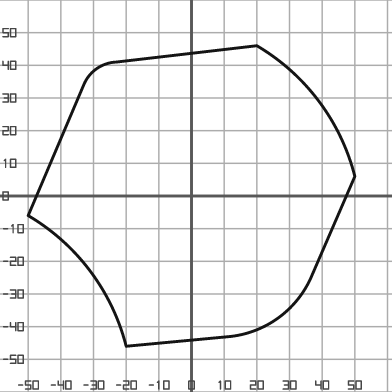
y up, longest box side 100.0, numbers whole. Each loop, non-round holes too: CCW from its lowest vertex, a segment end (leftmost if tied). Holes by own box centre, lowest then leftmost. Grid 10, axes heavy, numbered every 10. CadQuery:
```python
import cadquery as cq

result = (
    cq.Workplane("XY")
    .moveTo(-20.0, -46.0)
    .lineTo(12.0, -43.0)
    .threePointArc((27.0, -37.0), (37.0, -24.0))
    .lineTo(50.0, 6.0)
    .threePointArc((39.0, 29.0), (20.0, 46.0))
    .lineTo(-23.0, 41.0)
    .threePointArc((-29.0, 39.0), (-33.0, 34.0))
    .lineTo(-50.0, -6.0)
    .threePointArc((-31.0, -23.0), (-20.0, -46.0))
    .close()
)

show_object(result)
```